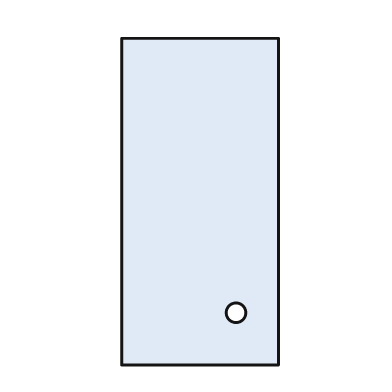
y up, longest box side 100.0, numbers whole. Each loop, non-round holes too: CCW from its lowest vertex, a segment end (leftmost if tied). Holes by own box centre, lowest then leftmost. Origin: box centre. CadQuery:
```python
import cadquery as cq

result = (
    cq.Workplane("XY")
    .moveTo(-24.0, -50.0)
    .lineTo(24.0, -50.0)
    .lineTo(24.0, 50.0)
    .lineTo(-24.0, 50.0)
    .close()
    .moveTo(11.0, -34.0)
    .circle(3.0)
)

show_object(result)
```